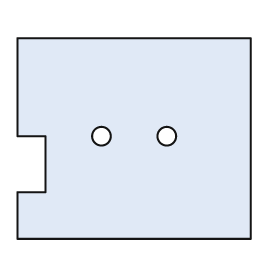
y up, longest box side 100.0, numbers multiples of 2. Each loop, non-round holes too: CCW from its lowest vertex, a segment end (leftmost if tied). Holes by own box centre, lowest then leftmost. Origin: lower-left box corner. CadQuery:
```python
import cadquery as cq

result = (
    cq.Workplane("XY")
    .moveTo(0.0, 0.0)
    .lineTo(100.0, 0.0)
    .lineTo(100.0, 86.0)
    .lineTo(0.0, 86.0)
    .lineTo(0.0, 44.0)
    .lineTo(12.0, 44.0)
    .lineTo(12.0, 20.0)
    .lineTo(0.0, 20.0)
    .close()
    .moveTo(36.0, 44.0)
    .circle(4.0)
    .moveTo(64.0, 44.0)
    .circle(4.0)
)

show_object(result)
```